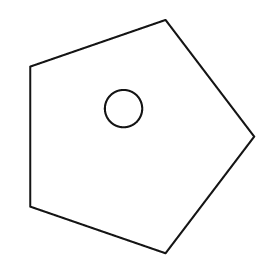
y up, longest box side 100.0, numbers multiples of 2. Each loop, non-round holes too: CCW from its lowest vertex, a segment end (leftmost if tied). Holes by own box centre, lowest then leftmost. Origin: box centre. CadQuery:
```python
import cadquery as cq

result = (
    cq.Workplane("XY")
    .moveTo(10.0, -50.0)
    .lineTo(48.0, 0.0)
    .lineTo(10.0, 50.0)
    .lineTo(-48.0, 30.0)
    .lineTo(-48.0, -30.0)
    .close()
    .moveTo(-8.0, 12.0)
    .circle(8.0)
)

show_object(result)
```